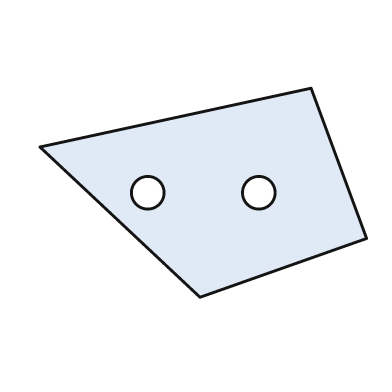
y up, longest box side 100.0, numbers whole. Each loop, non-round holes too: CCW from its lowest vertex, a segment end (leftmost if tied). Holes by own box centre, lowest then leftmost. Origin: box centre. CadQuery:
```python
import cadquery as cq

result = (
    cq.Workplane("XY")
    .moveTo(-1.0, -32.0)
    .lineTo(50.0, -14.0)
    .lineTo(33.0, 32.0)
    .lineTo(-50.0, 14.0)
    .close()
    .moveTo(-17.0, 0.0)
    .circle(5.0)
    .moveTo(17.0, 0.0)
    .circle(5.0)
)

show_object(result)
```